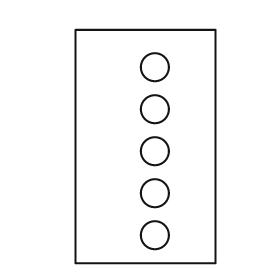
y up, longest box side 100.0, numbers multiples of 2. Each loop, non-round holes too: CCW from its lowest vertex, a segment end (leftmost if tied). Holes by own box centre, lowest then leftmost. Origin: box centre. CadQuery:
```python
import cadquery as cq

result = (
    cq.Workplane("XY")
    .moveTo(-30.0, -50.0)
    .lineTo(30.0, -50.0)
    .lineTo(30.0, 50.0)
    .lineTo(-30.0, 50.0)
    .close()
    .moveTo(4.0, -38.0)
    .circle(6.0)
    .moveTo(4.0, -20.0)
    .circle(6.0)
    .moveTo(4.0, -2.0)
    .circle(6.0)
    .moveTo(4.0, 16.0)
    .circle(6.0)
    .moveTo(4.0, 34.0)
    .circle(6.0)
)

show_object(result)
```